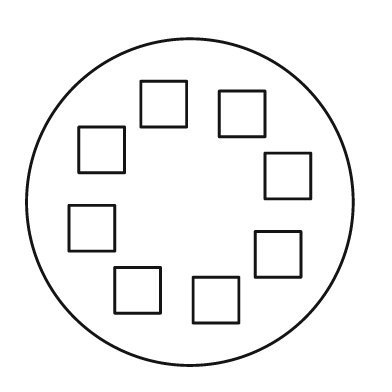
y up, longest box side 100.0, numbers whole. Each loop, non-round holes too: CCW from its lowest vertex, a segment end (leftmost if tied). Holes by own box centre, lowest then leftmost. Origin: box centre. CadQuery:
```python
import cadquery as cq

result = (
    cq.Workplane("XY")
    .moveTo(0.0, 0.0)
    .circle(50.0)
    .moveTo(1.0, -37.0)
    .lineTo(15.0, -37.0)
    .lineTo(15.0, -23.0)
    .lineTo(1.0, -23.0)
    .close()
    .moveTo(-23.0, -34.0)
    .lineTo(-9.0, -34.0)
    .lineTo(-9.0, -20.0)
    .lineTo(-23.0, -20.0)
    .close()
    .moveTo(20.0, -23.0)
    .lineTo(34.0, -23.0)
    .lineTo(34.0, -9.0)
    .lineTo(20.0, -9.0)
    .close()
    .moveTo(-37.0, -15.0)
    .lineTo(-23.0, -15.0)
    .lineTo(-23.0, -1.0)
    .lineTo(-37.0, -1.0)
    .close()
    .moveTo(23.0, 1.0)
    .lineTo(37.0, 1.0)
    .lineTo(37.0, 15.0)
    .lineTo(23.0, 15.0)
    .close()
    .moveTo(-34.0, 9.0)
    .lineTo(-20.0, 9.0)
    .lineTo(-20.0, 23.0)
    .lineTo(-34.0, 23.0)
    .close()
    .moveTo(9.0, 20.0)
    .lineTo(23.0, 20.0)
    .lineTo(23.0, 34.0)
    .lineTo(9.0, 34.0)
    .close()
    .moveTo(-15.0, 23.0)
    .lineTo(-1.0, 23.0)
    .lineTo(-1.0, 37.0)
    .lineTo(-15.0, 37.0)
    .close()
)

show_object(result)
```